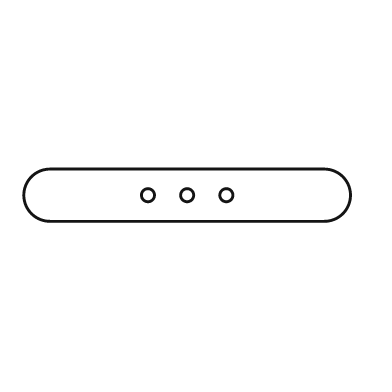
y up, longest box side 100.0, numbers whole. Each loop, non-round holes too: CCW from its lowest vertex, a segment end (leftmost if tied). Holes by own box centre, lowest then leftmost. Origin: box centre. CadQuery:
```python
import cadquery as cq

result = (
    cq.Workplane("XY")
    .moveTo(-42.0, -8.0)
    .lineTo(42.0, -8.0)
    .threePointArc((50.0, 0.0), (42.0, 8.0))
    .lineTo(-42.0, 8.0)
    .threePointArc((-50.0, 0.0), (-42.0, -8.0))
    .close()
    .moveTo(-12.0, 0.0)
    .circle(2.0)
    .moveTo(0.0, 0.0)
    .circle(2.0)
    .moveTo(12.0, 0.0)
    .circle(2.0)
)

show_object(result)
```